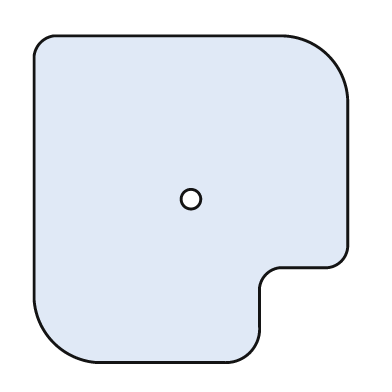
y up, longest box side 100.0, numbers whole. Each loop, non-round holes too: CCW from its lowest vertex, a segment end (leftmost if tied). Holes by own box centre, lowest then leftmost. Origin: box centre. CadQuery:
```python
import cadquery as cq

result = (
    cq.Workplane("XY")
    .moveTo(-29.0, -50.0)
    .lineTo(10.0, -50.0)
    .threePointArc((18.0, -47.0), (21.0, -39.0))
    .lineTo(21.0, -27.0)
    .threePointArc((23.0, -23.0), (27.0, -21.0))
    .lineTo(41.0, -21.0)
    .threePointArc((46.0, -19.0), (48.0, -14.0))
    .lineTo(48.0, 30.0)
    .threePointArc((42.0, 44.0), (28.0, 50.0))
    .lineTo(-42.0, 50.0)
    .threePointArc((-46.0, 48.0), (-48.0, 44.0))
    .lineTo(-48.0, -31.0)
    .threePointArc((-42.0, -44.0), (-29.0, -50.0))
    .close()
    .moveTo(0.0, 0.0)
    .circle(3.0)
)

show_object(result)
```